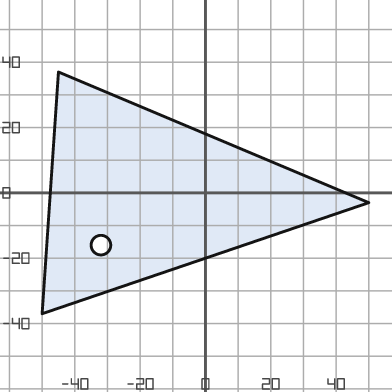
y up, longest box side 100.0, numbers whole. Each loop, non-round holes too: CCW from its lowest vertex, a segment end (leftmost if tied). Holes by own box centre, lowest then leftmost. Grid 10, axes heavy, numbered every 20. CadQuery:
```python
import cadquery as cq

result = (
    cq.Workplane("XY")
    .moveTo(-50.0, -37.0)
    .lineTo(50.0, -3.0)
    .lineTo(-45.0, 37.0)
    .close()
    .moveTo(-32.0, -16.0)
    .circle(3.0)
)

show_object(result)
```